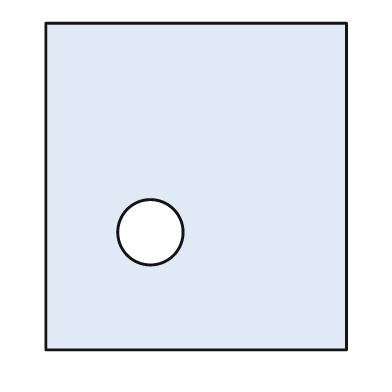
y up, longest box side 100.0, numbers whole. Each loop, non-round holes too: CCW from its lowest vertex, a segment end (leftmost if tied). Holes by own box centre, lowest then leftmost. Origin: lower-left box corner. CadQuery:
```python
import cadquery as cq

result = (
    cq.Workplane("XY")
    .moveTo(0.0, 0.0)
    .lineTo(92.0, 0.0)
    .lineTo(92.0, 100.0)
    .lineTo(0.0, 100.0)
    .close()
    .moveTo(32.0, 36.0)
    .circle(10.0)
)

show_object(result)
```